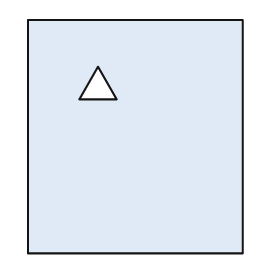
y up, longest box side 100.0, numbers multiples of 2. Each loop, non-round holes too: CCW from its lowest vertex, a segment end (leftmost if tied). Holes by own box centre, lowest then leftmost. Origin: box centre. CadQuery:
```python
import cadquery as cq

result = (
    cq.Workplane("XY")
    .moveTo(-46.0, -50.0)
    .lineTo(46.0, -50.0)
    .lineTo(46.0, 50.0)
    .lineTo(-46.0, 50.0)
    .close()
    .moveTo(-24.0, 16.0)
    .lineTo(-8.0, 16.0)
    .lineTo(-16.0, 30.0)
    .close()
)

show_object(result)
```